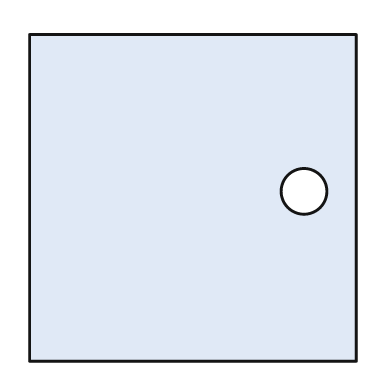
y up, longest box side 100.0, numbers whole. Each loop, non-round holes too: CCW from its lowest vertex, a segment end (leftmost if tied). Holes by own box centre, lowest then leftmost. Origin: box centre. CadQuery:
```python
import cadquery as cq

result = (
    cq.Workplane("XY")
    .moveTo(-50.0, -50.0)
    .lineTo(50.0, -50.0)
    .lineTo(50.0, 50.0)
    .lineTo(-50.0, 50.0)
    .close()
    .moveTo(34.0, 2.0)
    .circle(7.0)
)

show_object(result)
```